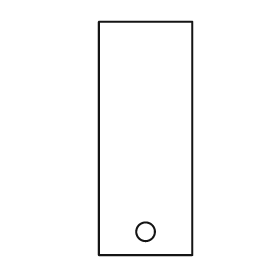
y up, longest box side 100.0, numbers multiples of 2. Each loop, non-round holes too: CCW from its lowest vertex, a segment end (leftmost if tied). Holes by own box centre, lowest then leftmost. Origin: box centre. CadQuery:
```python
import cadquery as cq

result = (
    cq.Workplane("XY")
    .moveTo(-20.0, -50.0)
    .lineTo(20.0, -50.0)
    .lineTo(20.0, 50.0)
    .lineTo(-20.0, 50.0)
    .close()
    .moveTo(0.0, -40.0)
    .circle(4.0)
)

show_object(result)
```